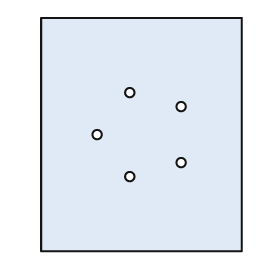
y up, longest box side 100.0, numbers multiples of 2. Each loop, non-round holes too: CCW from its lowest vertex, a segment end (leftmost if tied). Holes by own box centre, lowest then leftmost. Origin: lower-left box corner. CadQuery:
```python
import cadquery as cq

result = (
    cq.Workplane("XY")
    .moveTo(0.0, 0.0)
    .lineTo(86.0, 0.0)
    .lineTo(86.0, 100.0)
    .lineTo(0.0, 100.0)
    .close()
    .moveTo(38.0, 32.0)
    .circle(2.0)
    .moveTo(60.0, 38.0)
    .circle(2.0)
    .moveTo(24.0, 50.0)
    .circle(2.0)
    .moveTo(60.0, 62.0)
    .circle(2.0)
    .moveTo(38.0, 68.0)
    .circle(2.0)
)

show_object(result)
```